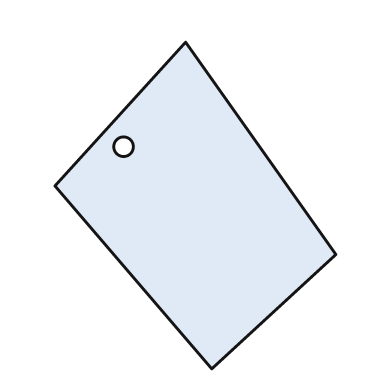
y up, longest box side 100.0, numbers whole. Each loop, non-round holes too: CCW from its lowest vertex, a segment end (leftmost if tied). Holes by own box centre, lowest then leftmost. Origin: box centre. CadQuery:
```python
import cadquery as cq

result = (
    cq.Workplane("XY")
    .moveTo(5.0, -50.0)
    .lineTo(43.0, -15.0)
    .lineTo(-3.0, 50.0)
    .lineTo(-43.0, 6.0)
    .close()
    .moveTo(-22.0, 18.0)
    .circle(3.0)
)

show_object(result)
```